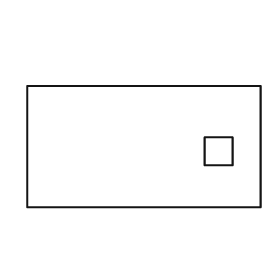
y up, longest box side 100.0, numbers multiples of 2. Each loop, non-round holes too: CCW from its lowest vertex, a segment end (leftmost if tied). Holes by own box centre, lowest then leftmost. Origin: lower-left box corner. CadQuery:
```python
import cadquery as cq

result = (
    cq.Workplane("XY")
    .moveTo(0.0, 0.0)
    .lineTo(100.0, 0.0)
    .lineTo(100.0, 52.0)
    .lineTo(0.0, 52.0)
    .close()
    .moveTo(76.0, 18.0)
    .lineTo(88.0, 18.0)
    .lineTo(88.0, 30.0)
    .lineTo(76.0, 30.0)
    .close()
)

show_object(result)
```